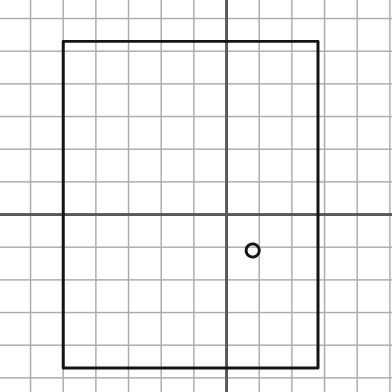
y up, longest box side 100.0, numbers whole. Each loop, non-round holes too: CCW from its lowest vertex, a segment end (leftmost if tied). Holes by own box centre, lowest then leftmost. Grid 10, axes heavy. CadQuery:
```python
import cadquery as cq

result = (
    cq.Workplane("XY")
    .moveTo(-50.0, -47.0)
    .lineTo(28.0, -47.0)
    .lineTo(28.0, 53.0)
    .lineTo(-50.0, 53.0)
    .close()
    .moveTo(8.0, -11.0)
    .circle(2.0)
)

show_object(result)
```